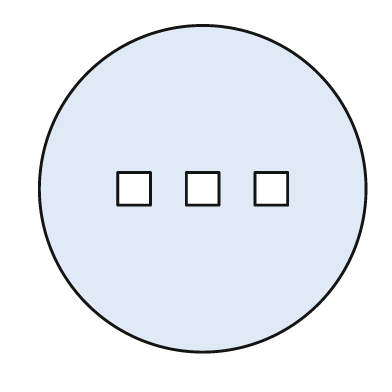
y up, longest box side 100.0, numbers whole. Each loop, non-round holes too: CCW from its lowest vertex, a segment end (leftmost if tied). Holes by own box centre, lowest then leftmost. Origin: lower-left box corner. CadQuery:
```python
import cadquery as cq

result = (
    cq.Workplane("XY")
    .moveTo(50.0, 50.0)
    .circle(50.0)
    .moveTo(24.0, 45.0)
    .lineTo(34.0, 45.0)
    .lineTo(34.0, 55.0)
    .lineTo(24.0, 55.0)
    .close()
    .moveTo(45.0, 45.0)
    .lineTo(55.0, 45.0)
    .lineTo(55.0, 55.0)
    .lineTo(45.0, 55.0)
    .close()
    .moveTo(66.0, 45.0)
    .lineTo(76.0, 45.0)
    .lineTo(76.0, 55.0)
    .lineTo(66.0, 55.0)
    .close()
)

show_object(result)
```